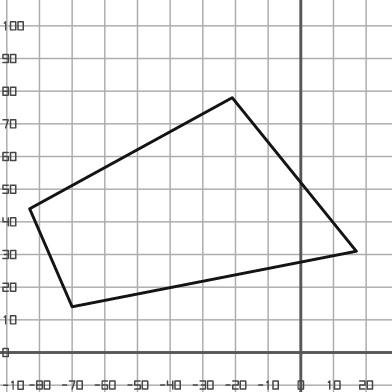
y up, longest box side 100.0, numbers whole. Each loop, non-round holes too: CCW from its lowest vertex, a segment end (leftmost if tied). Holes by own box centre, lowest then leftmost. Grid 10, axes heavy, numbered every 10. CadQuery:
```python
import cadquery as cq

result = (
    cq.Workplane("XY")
    .moveTo(-70.0, 14.0)
    .lineTo(17.0, 31.0)
    .lineTo(-21.0, 78.0)
    .lineTo(-83.0, 44.0)
    .close()
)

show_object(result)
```